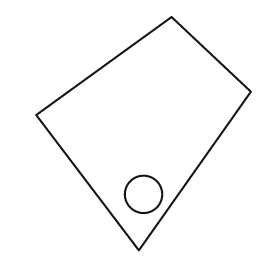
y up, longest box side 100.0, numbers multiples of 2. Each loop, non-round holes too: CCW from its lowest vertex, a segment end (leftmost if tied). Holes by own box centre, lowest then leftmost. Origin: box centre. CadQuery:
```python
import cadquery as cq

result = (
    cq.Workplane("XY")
    .moveTo(-2.0, -50.0)
    .lineTo(46.0, 18.0)
    .lineTo(12.0, 50.0)
    .lineTo(-46.0, 8.0)
    .close()
    .moveTo(0.0, -26.0)
    .circle(8.0)
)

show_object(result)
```